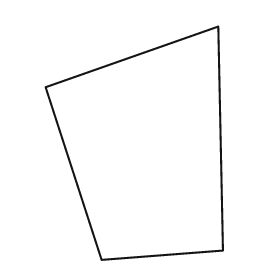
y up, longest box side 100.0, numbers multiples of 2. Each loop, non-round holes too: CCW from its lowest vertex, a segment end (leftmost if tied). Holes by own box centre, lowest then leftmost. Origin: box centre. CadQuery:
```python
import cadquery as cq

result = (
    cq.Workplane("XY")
    .moveTo(-14.0, -50.0)
    .lineTo(38.0, -46.0)
    .lineTo(36.0, 50.0)
    .lineTo(-38.0, 24.0)
    .close()
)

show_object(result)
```